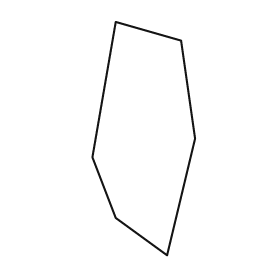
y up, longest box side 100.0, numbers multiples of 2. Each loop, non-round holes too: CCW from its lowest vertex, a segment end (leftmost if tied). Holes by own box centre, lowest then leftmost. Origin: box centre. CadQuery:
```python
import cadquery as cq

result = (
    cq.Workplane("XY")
    .moveTo(10.0, -50.0)
    .lineTo(22.0, 0.0)
    .lineTo(16.0, 42.0)
    .lineTo(-12.0, 50.0)
    .lineTo(-22.0, -8.0)
    .lineTo(-12.0, -34.0)
    .close()
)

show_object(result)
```